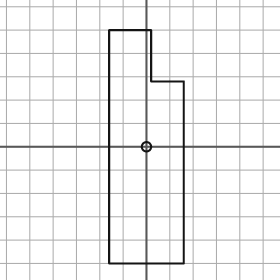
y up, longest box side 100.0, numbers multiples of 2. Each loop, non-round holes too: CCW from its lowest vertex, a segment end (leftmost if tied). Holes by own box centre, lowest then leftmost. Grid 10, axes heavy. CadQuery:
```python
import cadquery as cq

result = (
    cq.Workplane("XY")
    .moveTo(-16.0, -50.0)
    .lineTo(16.0, -50.0)
    .lineTo(16.0, 28.0)
    .lineTo(2.0, 28.0)
    .lineTo(2.0, 50.0)
    .lineTo(-16.0, 50.0)
    .close()
    .moveTo(0.0, 0.0)
    .circle(2.0)
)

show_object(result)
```